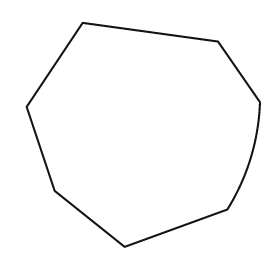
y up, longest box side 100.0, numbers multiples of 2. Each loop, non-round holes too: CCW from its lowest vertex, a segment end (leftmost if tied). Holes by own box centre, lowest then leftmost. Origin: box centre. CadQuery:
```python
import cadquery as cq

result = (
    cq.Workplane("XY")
    .moveTo(-8.0, -48.0)
    .lineTo(36.0, -32.0)
    .threePointArc((46.0, -10.0), (50.0, 14.0))
    .lineTo(32.0, 40.0)
    .lineTo(-26.0, 48.0)
    .lineTo(-50.0, 12.0)
    .lineTo(-38.0, -24.0)
    .close()
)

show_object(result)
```